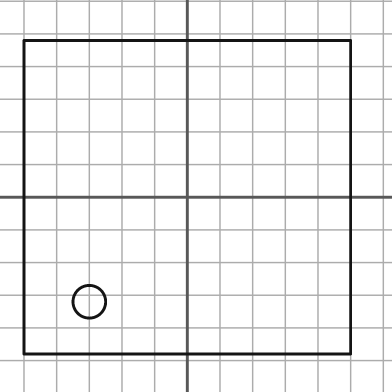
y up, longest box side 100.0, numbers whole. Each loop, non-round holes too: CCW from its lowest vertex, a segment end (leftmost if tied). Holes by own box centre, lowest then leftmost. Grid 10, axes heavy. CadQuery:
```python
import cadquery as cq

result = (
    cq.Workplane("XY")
    .moveTo(-50.0, -48.0)
    .lineTo(50.0, -48.0)
    .lineTo(50.0, 48.0)
    .lineTo(-50.0, 48.0)
    .close()
    .moveTo(-30.0, -32.0)
    .circle(5.0)
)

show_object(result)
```